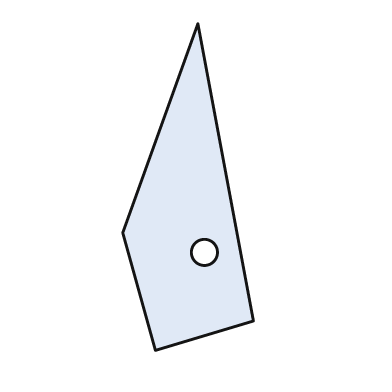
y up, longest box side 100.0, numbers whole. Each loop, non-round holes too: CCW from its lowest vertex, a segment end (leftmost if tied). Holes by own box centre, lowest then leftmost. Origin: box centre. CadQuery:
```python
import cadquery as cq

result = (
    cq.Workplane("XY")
    .moveTo(-10.0, -50.0)
    .lineTo(20.0, -41.0)
    .lineTo(3.0, 50.0)
    .lineTo(-20.0, -14.0)
    .close()
    .moveTo(5.0, -20.0)
    .circle(4.0)
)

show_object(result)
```